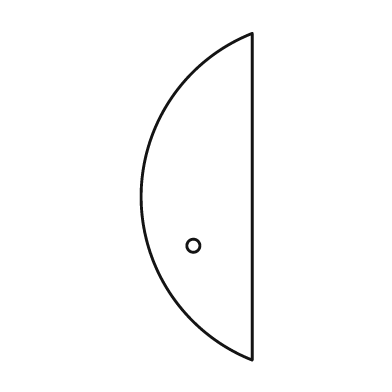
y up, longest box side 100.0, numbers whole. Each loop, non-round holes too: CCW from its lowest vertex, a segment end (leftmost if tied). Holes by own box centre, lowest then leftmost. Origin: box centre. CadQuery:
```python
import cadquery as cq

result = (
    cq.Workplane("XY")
    .moveTo(17.0, -50.0)
    .lineTo(17.0, 50.0)
    .threePointArc((-17.0, 0.0), (17.0, -50.0))
    .close()
    .moveTo(-1.0, -15.0)
    .circle(2.0)
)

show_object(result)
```